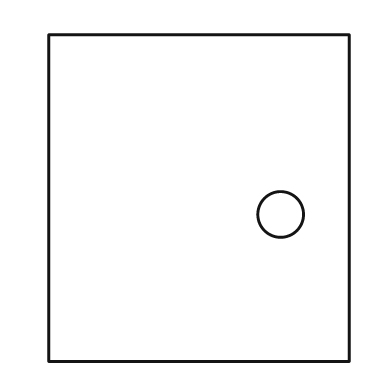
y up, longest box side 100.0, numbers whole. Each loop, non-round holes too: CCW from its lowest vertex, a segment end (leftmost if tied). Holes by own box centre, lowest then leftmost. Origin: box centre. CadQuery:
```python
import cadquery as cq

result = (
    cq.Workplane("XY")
    .moveTo(-46.0, -50.0)
    .lineTo(46.0, -50.0)
    .lineTo(46.0, 50.0)
    .lineTo(-46.0, 50.0)
    .close()
    .moveTo(25.0, -5.0)
    .circle(7.0)
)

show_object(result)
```